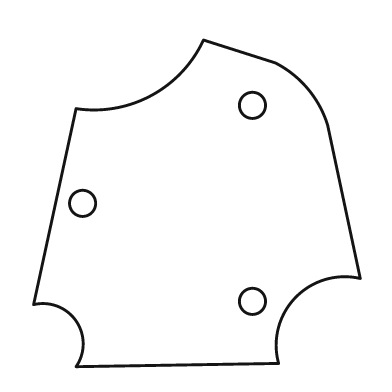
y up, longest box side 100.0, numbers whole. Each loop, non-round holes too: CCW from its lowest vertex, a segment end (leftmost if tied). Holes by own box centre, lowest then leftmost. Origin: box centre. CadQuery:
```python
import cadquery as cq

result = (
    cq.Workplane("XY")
    .moveTo(-37.0, -50.0)
    .lineTo(25.0, -49.0)
    .threePointArc((30.0, -29.0), (50.0, -23.0))
    .lineTo(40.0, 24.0)
    .threePointArc((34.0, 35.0), (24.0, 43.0))
    .lineTo(2.0, 50.0)
    .threePointArc((-14.0, 33.0), (-37.0, 29.0))
    .lineTo(-50.0, -31.0)
    .threePointArc((-37.0, -36.0), (-37.0, -50.0))
    .close()
    .moveTo(17.0, -30.0)
    .circle(4.0)
    .moveTo(-35.0, 0.0)
    .circle(4.0)
    .moveTo(17.0, 30.0)
    .circle(4.0)
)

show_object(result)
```